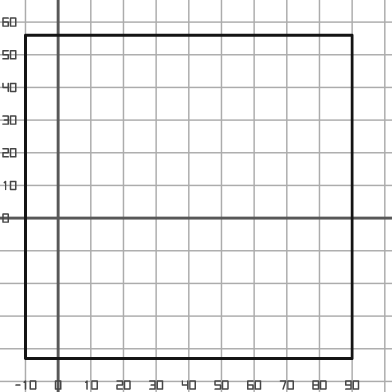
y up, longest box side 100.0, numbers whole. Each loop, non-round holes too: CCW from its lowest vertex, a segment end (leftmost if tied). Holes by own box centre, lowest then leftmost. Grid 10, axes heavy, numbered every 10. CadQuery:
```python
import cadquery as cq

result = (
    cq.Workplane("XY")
    .moveTo(-10.0, -43.0)
    .lineTo(90.0, -43.0)
    .lineTo(90.0, 56.0)
    .lineTo(-10.0, 56.0)
    .close()
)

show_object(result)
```